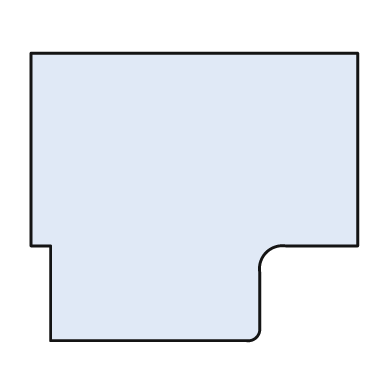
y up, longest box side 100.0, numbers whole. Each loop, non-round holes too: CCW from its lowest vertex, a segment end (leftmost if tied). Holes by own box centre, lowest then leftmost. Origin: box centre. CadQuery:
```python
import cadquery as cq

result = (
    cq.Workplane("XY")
    .moveTo(-44.0, -44.0)
    .lineTo(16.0, -44.0)
    .threePointArc((19.0, -43.0), (20.0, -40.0))
    .lineTo(20.0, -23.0)
    .threePointArc((22.0, -17.0), (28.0, -15.0))
    .lineTo(50.0, -15.0)
    .lineTo(50.0, 44.0)
    .lineTo(-50.0, 44.0)
    .lineTo(-50.0, -15.0)
    .lineTo(-44.0, -15.0)
    .close()
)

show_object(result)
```